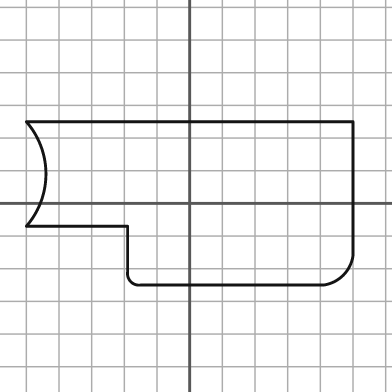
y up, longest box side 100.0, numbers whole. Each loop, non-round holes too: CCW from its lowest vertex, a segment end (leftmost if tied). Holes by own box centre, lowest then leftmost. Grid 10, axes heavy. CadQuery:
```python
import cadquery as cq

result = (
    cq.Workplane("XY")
    .moveTo(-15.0, -25.0)
    .lineTo(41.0, -25.0)
    .threePointArc((47.0, -22.0), (50.0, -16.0))
    .lineTo(50.0, 25.0)
    .lineTo(-50.0, 25.0)
    .threePointArc((-44.0, 9.0), (-50.0, -7.0))
    .lineTo(-19.0, -7.0)
    .lineTo(-19.0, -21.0)
    .threePointArc((-18.0, -24.0), (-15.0, -25.0))
    .close()
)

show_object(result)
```